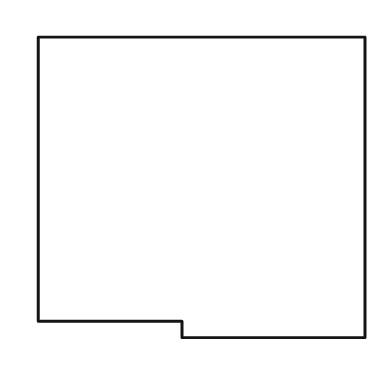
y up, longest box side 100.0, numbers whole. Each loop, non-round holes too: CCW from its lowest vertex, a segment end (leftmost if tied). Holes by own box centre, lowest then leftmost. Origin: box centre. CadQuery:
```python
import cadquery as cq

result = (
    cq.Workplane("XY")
    .moveTo(-6.0, -46.0)
    .lineTo(50.0, -46.0)
    .lineTo(50.0, 46.0)
    .lineTo(-50.0, 46.0)
    .lineTo(-50.0, -41.0)
    .lineTo(-6.0, -41.0)
    .close()
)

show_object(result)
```